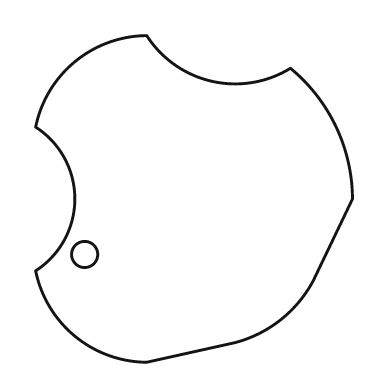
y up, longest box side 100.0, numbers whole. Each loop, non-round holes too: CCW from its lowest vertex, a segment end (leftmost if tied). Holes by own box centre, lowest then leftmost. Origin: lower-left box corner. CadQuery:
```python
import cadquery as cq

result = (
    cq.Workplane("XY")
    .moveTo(34.0, 0.0)
    .lineTo(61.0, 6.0)
    .threePointArc((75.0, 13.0), (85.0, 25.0))
    .lineTo(97.0, 50.0)
    .threePointArc((92.0, 72.0), (78.0, 90.0))
    .threePointArc((54.0, 86.0), (34.0, 100.0))
    .threePointArc((12.0, 92.0), (0.0, 72.0))
    .threePointArc((12.0, 50.0), (0.0, 28.0))
    .threePointArc((12.0, 8.0), (34.0, 0.0))
    .close()
    .moveTo(15.0, 33.0)
    .circle(4.0)
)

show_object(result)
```